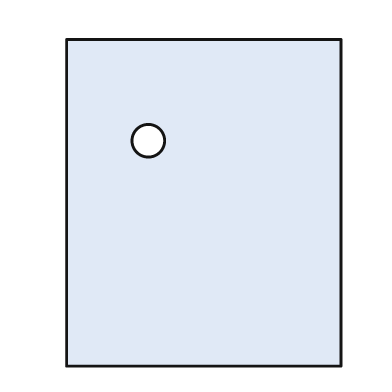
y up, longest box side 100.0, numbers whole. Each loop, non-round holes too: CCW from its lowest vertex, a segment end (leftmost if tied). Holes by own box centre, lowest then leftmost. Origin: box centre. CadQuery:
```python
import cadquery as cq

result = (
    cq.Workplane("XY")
    .moveTo(-42.0, -50.0)
    .lineTo(42.0, -50.0)
    .lineTo(42.0, 50.0)
    .lineTo(-42.0, 50.0)
    .close()
    .moveTo(-17.0, 19.0)
    .circle(5.0)
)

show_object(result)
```